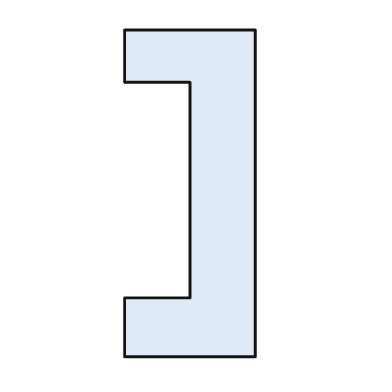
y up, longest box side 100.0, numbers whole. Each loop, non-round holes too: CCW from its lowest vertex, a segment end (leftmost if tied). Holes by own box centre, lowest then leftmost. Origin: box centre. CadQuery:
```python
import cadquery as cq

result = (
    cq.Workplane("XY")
    .moveTo(-20.0, -50.0)
    .lineTo(20.0, -50.0)
    .lineTo(20.0, 50.0)
    .lineTo(-20.0, 50.0)
    .lineTo(-20.0, 34.0)
    .lineTo(0.0, 34.0)
    .lineTo(0.0, -32.0)
    .lineTo(-20.0, -32.0)
    .close()
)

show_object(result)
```